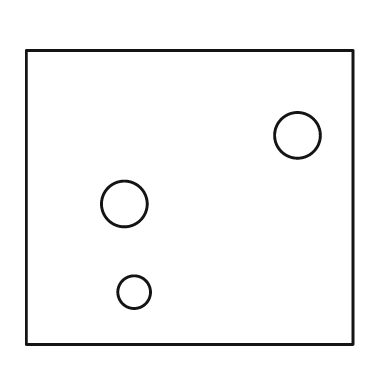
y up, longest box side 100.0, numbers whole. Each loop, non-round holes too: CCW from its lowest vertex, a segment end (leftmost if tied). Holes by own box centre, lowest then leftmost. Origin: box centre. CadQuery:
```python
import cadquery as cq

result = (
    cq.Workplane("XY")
    .moveTo(-50.0, -45.0)
    .lineTo(50.0, -45.0)
    .lineTo(50.0, 45.0)
    .lineTo(-50.0, 45.0)
    .close()
    .moveTo(-17.0, -29.0)
    .circle(5.0)
    .moveTo(-20.0, -2.0)
    .circle(7.0)
    .moveTo(33.0, 19.0)
    .circle(7.0)
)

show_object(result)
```